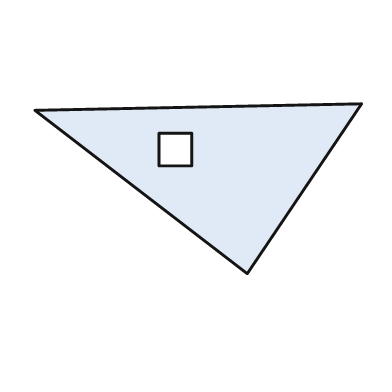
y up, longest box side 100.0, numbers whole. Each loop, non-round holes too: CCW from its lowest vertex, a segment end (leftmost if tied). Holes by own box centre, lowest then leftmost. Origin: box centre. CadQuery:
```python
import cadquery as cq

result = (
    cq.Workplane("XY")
    .moveTo(15.0, -26.0)
    .lineTo(50.0, 26.0)
    .lineTo(-50.0, 24.0)
    .close()
    .moveTo(-12.0, 7.0)
    .lineTo(-2.0, 7.0)
    .lineTo(-2.0, 17.0)
    .lineTo(-12.0, 17.0)
    .close()
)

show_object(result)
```